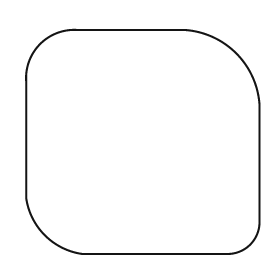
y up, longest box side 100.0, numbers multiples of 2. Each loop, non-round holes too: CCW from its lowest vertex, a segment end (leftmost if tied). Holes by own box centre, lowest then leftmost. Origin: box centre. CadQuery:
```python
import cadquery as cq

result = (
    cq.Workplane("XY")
    .moveTo(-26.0, -48.0)
    .lineTo(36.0, -48.0)
    .threePointArc((46.0, -44.0), (50.0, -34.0))
    .lineTo(50.0, 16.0)
    .threePointArc((40.0, 38.0), (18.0, 48.0))
    .lineTo(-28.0, 48.0)
    .threePointArc((-44.0, 42.0), (-50.0, 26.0))
    .lineTo(-50.0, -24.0)
    .threePointArc((-42.0, -40.0), (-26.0, -48.0))
    .close()
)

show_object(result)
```